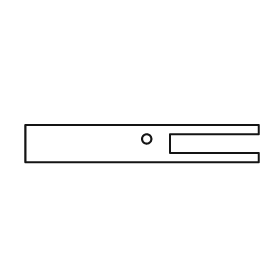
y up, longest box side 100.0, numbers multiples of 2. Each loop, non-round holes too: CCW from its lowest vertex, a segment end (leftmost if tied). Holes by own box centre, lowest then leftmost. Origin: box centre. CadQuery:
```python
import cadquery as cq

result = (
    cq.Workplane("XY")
    .moveTo(-50.0, -8.0)
    .lineTo(50.0, -8.0)
    .lineTo(50.0, -4.0)
    .lineTo(12.0, -4.0)
    .lineTo(12.0, 4.0)
    .lineTo(50.0, 4.0)
    .lineTo(50.0, 8.0)
    .lineTo(-50.0, 8.0)
    .close()
    .moveTo(2.0, 2.0)
    .circle(2.0)
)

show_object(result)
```